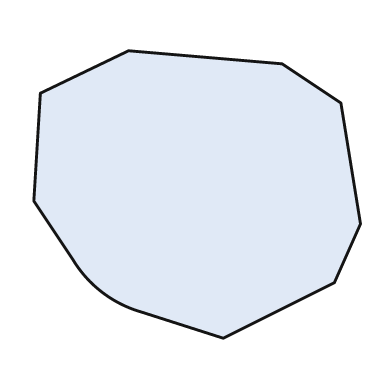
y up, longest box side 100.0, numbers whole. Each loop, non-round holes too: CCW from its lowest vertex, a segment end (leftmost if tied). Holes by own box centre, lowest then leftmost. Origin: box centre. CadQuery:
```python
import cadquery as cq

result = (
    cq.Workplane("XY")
    .moveTo(8.0, -44.0)
    .lineTo(42.0, -27.0)
    .lineTo(50.0, -9.0)
    .lineTo(44.0, 28.0)
    .lineTo(26.0, 40.0)
    .lineTo(-21.0, 44.0)
    .lineTo(-48.0, 31.0)
    .lineTo(-50.0, -2.0)
    .lineTo(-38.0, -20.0)
    .threePointArc((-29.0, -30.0), (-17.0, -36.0))
    .close()
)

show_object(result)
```